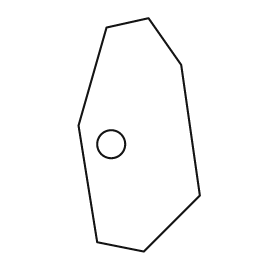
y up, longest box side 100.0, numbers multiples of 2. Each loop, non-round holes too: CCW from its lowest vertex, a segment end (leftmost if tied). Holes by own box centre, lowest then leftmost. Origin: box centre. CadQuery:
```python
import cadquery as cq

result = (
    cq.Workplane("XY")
    .moveTo(2.0, -50.0)
    .lineTo(26.0, -26.0)
    .lineTo(18.0, 30.0)
    .lineTo(4.0, 50.0)
    .lineTo(-14.0, 46.0)
    .lineTo(-26.0, 4.0)
    .lineTo(-18.0, -46.0)
    .close()
    .moveTo(-12.0, -4.0)
    .circle(6.0)
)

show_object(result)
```